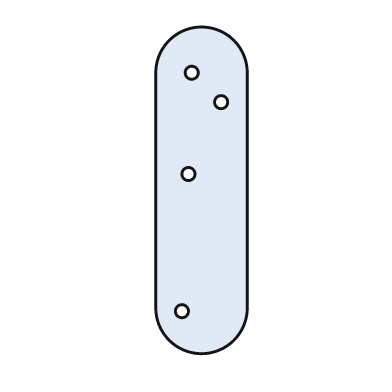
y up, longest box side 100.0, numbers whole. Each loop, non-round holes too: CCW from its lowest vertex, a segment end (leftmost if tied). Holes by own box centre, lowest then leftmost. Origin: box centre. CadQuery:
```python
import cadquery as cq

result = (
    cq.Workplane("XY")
    .moveTo(-14.0, -36.0)
    .threePointArc((0.0, -50.0), (14.0, -36.0))
    .lineTo(14.0, 36.0)
    .threePointArc((0.0, 50.0), (-14.0, 36.0))
    .close()
    .moveTo(-6.0, -37.0)
    .circle(2.0)
    .moveTo(-4.0, 5.0)
    .circle(2.0)
    .moveTo(6.0, 27.0)
    .circle(2.0)
    .moveTo(-3.0, 36.0)
    .circle(2.0)
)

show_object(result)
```